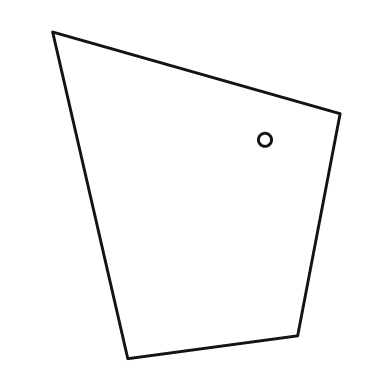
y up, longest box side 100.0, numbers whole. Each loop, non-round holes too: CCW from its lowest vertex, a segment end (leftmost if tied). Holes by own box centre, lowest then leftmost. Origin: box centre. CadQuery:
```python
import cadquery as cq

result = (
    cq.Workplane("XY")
    .moveTo(-21.0, -50.0)
    .lineTo(31.0, -43.0)
    .lineTo(44.0, 25.0)
    .lineTo(-44.0, 50.0)
    .close()
    .moveTo(21.0, 17.0)
    .circle(2.0)
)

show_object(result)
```